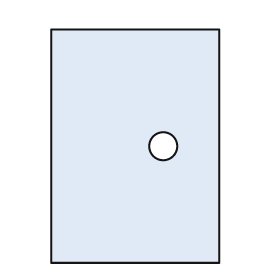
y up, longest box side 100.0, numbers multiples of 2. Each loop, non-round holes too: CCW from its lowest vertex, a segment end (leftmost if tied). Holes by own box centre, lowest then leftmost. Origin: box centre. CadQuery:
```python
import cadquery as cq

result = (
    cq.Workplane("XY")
    .moveTo(-36.0, -50.0)
    .lineTo(36.0, -50.0)
    .lineTo(36.0, 50.0)
    .lineTo(-36.0, 50.0)
    .close()
    .moveTo(12.0, 0.0)
    .circle(6.0)
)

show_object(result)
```